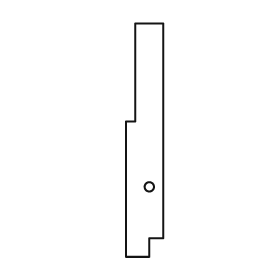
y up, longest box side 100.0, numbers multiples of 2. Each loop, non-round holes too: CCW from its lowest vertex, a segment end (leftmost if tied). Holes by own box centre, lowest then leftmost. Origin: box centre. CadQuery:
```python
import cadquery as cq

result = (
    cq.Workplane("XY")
    .moveTo(-8.0, -50.0)
    .lineTo(2.0, -50.0)
    .lineTo(2.0, -42.0)
    .lineTo(8.0, -42.0)
    .lineTo(8.0, 50.0)
    .lineTo(-4.0, 50.0)
    .lineTo(-4.0, 8.0)
    .lineTo(-8.0, 8.0)
    .close()
    .moveTo(2.0, -20.0)
    .circle(2.0)
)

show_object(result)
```